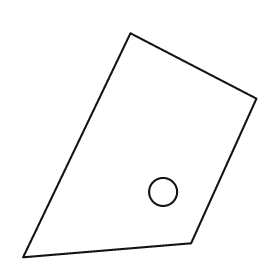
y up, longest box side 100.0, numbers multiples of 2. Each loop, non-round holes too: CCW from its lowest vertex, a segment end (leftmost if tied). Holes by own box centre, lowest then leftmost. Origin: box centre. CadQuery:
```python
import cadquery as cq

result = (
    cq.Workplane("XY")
    .moveTo(-50.0, -48.0)
    .lineTo(22.0, -42.0)
    .lineTo(50.0, 20.0)
    .lineTo(-4.0, 48.0)
    .close()
    .moveTo(10.0, -20.0)
    .circle(6.0)
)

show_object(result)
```